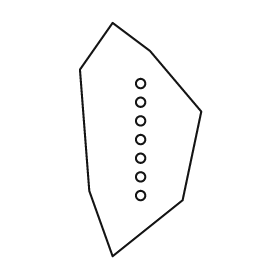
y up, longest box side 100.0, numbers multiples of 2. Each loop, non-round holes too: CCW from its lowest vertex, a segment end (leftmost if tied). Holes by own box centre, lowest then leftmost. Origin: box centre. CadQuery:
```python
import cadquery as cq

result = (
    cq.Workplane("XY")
    .moveTo(-12.0, -50.0)
    .lineTo(18.0, -26.0)
    .lineTo(26.0, 12.0)
    .lineTo(4.0, 38.0)
    .lineTo(-12.0, 50.0)
    .lineTo(-26.0, 30.0)
    .lineTo(-22.0, -22.0)
    .close()
    .moveTo(0.0, -24.0)
    .circle(2.0)
    .moveTo(0.0, -16.0)
    .circle(2.0)
    .moveTo(0.0, -8.0)
    .circle(2.0)
    .moveTo(0.0, 0.0)
    .circle(2.0)
    .moveTo(0.0, 8.0)
    .circle(2.0)
    .moveTo(0.0, 16.0)
    .circle(2.0)
    .moveTo(0.0, 24.0)
    .circle(2.0)
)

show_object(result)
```